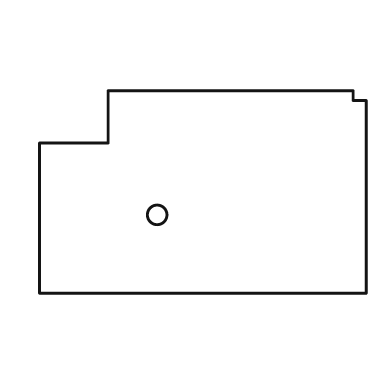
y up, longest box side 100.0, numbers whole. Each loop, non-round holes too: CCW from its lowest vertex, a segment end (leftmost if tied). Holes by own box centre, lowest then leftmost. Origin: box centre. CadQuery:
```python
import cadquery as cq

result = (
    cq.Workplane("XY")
    .moveTo(-50.0, -31.0)
    .lineTo(50.0, -31.0)
    .lineTo(50.0, 28.0)
    .lineTo(46.0, 28.0)
    .lineTo(46.0, 31.0)
    .lineTo(-29.0, 31.0)
    .lineTo(-29.0, 15.0)
    .lineTo(-50.0, 15.0)
    .close()
    .moveTo(-14.0, -7.0)
    .circle(3.0)
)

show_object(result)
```